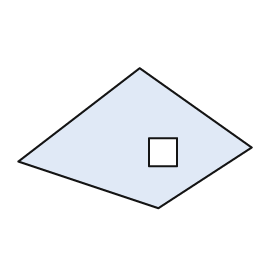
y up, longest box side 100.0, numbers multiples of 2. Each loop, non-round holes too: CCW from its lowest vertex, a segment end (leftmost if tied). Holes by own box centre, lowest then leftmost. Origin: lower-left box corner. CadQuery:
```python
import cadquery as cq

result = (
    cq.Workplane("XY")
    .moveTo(60.0, 0.0)
    .lineTo(100.0, 26.0)
    .lineTo(52.0, 60.0)
    .lineTo(0.0, 20.0)
    .close()
    .moveTo(56.0, 18.0)
    .lineTo(68.0, 18.0)
    .lineTo(68.0, 30.0)
    .lineTo(56.0, 30.0)
    .close()
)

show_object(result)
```